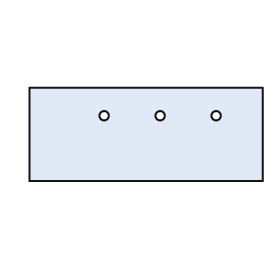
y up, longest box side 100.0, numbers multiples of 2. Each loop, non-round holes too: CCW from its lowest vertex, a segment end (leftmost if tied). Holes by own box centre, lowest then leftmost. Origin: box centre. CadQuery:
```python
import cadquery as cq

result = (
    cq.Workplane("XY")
    .moveTo(-50.0, -20.0)
    .lineTo(50.0, -20.0)
    .lineTo(50.0, 20.0)
    .lineTo(-50.0, 20.0)
    .close()
    .moveTo(-18.0, 8.0)
    .circle(2.0)
    .moveTo(6.0, 8.0)
    .circle(2.0)
    .moveTo(30.0, 8.0)
    .circle(2.0)
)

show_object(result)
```